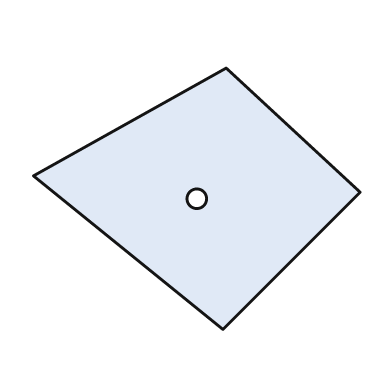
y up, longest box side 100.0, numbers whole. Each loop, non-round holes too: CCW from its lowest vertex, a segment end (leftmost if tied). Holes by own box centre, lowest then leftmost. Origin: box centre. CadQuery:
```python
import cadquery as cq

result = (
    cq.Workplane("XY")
    .moveTo(8.0, -40.0)
    .lineTo(50.0, 2.0)
    .lineTo(9.0, 40.0)
    .lineTo(-50.0, 7.0)
    .close()
    .moveTo(0.0, 0.0)
    .circle(3.0)
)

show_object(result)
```